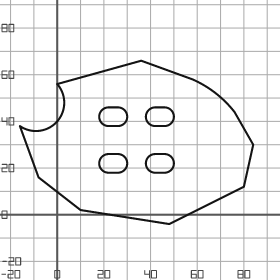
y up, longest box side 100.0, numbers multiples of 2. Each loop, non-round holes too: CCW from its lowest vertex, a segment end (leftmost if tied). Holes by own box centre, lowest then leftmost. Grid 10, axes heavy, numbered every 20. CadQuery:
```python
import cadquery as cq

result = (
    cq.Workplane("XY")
    .moveTo(48.0, -4.0)
    .lineTo(80.0, 12.0)
    .lineTo(84.0, 30.0)
    .lineTo(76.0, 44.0)
    .threePointArc((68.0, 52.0), (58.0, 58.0))
    .lineTo(36.0, 66.0)
    .lineTo(0.0, 56.0)
    .threePointArc((0.0, 40.0), (-16.0, 38.0))
    .lineTo(-8.0, 16.0)
    .lineTo(10.0, 2.0)
    .close()
    .moveTo(22.0, 18.0)
    .lineTo(26.0, 18.0)
    .threePointArc((30.0, 22.0), (26.0, 26.0))
    .lineTo(22.0, 26.0)
    .threePointArc((18.0, 22.0), (22.0, 18.0))
    .close()
    .moveTo(42.0, 18.0)
    .lineTo(46.0, 18.0)
    .threePointArc((50.0, 22.0), (46.0, 26.0))
    .lineTo(42.0, 26.0)
    .threePointArc((38.0, 22.0), (42.0, 18.0))
    .close()
    .moveTo(22.0, 38.0)
    .lineTo(26.0, 38.0)
    .threePointArc((30.0, 42.0), (26.0, 46.0))
    .lineTo(22.0, 46.0)
    .threePointArc((18.0, 42.0), (22.0, 38.0))
    .close()
    .moveTo(42.0, 38.0)
    .lineTo(46.0, 38.0)
    .threePointArc((50.0, 42.0), (46.0, 46.0))
    .lineTo(42.0, 46.0)
    .threePointArc((38.0, 42.0), (42.0, 38.0))
    .close()
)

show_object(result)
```